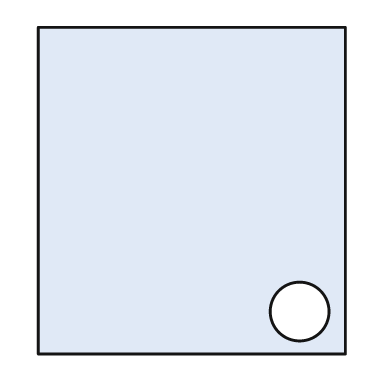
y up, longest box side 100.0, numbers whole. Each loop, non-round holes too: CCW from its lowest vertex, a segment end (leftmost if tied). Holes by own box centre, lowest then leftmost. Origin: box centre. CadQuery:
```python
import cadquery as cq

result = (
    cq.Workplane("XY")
    .moveTo(-47.0, -50.0)
    .lineTo(47.0, -50.0)
    .lineTo(47.0, 50.0)
    .lineTo(-47.0, 50.0)
    .close()
    .moveTo(33.0, -37.0)
    .circle(9.0)
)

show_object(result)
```